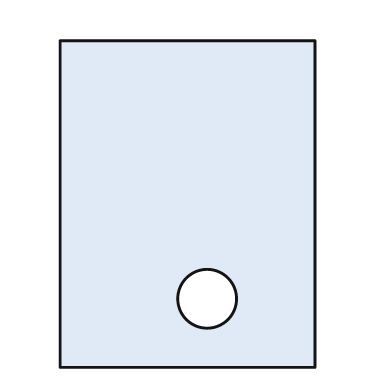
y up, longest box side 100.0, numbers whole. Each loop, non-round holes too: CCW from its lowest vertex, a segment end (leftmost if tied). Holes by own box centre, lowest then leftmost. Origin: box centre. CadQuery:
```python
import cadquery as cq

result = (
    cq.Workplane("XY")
    .moveTo(-39.0, -50.0)
    .lineTo(39.0, -50.0)
    .lineTo(39.0, 50.0)
    .lineTo(-39.0, 50.0)
    .close()
    .moveTo(6.0, -29.0)
    .circle(9.0)
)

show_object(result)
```